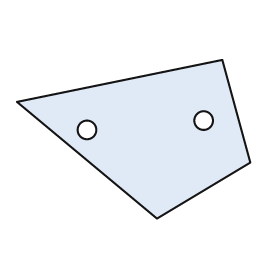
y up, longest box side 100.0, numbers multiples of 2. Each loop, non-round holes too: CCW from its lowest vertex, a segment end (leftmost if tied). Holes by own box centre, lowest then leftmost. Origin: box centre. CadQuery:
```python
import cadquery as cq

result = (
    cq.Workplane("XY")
    .moveTo(10.0, -34.0)
    .lineTo(50.0, -10.0)
    .lineTo(38.0, 34.0)
    .lineTo(-50.0, 16.0)
    .close()
    .moveTo(-20.0, 4.0)
    .circle(4.0)
    .moveTo(30.0, 8.0)
    .circle(4.0)
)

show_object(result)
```